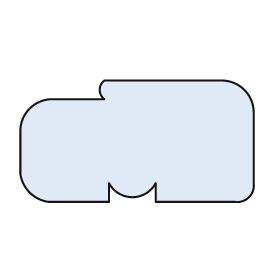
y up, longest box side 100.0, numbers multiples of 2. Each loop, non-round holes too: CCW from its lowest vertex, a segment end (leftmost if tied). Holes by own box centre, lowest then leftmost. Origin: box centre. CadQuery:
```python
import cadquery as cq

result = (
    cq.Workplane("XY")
    .moveTo(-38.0, -26.0)
    .lineTo(-12.0, -26.0)
    .lineTo(-12.0, -18.0)
    .threePointArc((-2.0, -24.0), (8.0, -18.0))
    .lineTo(8.0, -26.0)
    .lineTo(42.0, -26.0)
    .threePointArc((48.0, -24.0), (50.0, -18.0))
    .lineTo(50.0, 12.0)
    .threePointArc((46.0, 22.0), (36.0, 26.0))
    .lineTo(-14.0, 26.0)
    .threePointArc((-16.0, 22.0), (-14.0, 18.0))
    .lineTo(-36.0, 18.0)
    .threePointArc((-46.0, 14.0), (-50.0, 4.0))
    .lineTo(-50.0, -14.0)
    .threePointArc((-46.0, -22.0), (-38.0, -26.0))
    .close()
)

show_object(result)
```